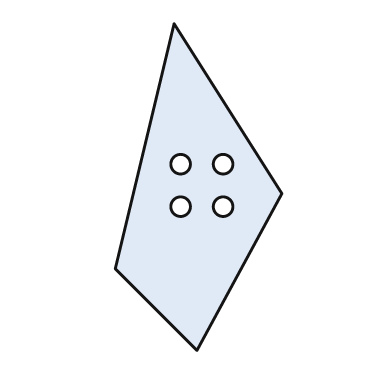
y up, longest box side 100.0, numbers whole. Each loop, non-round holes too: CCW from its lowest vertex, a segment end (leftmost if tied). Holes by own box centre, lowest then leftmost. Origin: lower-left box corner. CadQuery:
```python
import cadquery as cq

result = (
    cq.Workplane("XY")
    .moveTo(25.0, 0.0)
    .lineTo(51.0, 48.0)
    .lineTo(18.0, 100.0)
    .lineTo(0.0, 25.0)
    .close()
    .moveTo(20.0, 44.0)
    .circle(3.0)
    .moveTo(33.0, 44.0)
    .circle(3.0)
    .moveTo(20.0, 57.0)
    .circle(3.0)
    .moveTo(33.0, 57.0)
    .circle(3.0)
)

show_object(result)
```